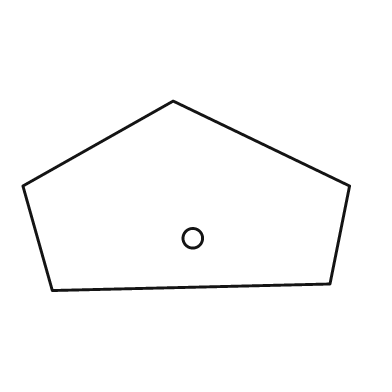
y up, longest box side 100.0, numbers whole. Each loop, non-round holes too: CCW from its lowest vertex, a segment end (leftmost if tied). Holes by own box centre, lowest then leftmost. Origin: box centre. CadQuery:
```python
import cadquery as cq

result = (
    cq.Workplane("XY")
    .moveTo(-41.0, -29.0)
    .lineTo(44.0, -27.0)
    .lineTo(50.0, 3.0)
    .lineTo(-4.0, 29.0)
    .lineTo(-50.0, 3.0)
    .close()
    .moveTo(2.0, -13.0)
    .circle(3.0)
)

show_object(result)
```